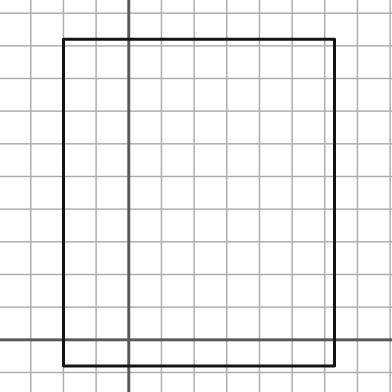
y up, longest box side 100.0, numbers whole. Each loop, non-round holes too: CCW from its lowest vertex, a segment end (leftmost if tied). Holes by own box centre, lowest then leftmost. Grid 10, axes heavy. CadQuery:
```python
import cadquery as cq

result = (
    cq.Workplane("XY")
    .moveTo(-20.0, -8.0)
    .lineTo(63.0, -8.0)
    .lineTo(63.0, 92.0)
    .lineTo(-20.0, 92.0)
    .close()
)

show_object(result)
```